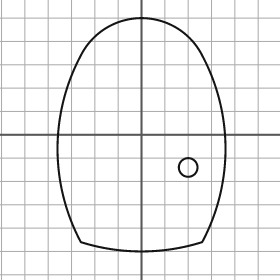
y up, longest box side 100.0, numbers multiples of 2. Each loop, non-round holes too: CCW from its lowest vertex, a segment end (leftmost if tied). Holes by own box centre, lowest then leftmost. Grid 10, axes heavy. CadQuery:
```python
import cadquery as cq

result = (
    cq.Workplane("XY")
    .moveTo(-26.0, -46.0)
    .threePointArc((0.0, -50.0), (26.0, -46.0))
    .threePointArc((36.0, -6.0), (26.0, 34.0))
    .threePointArc((0.0, 50.0), (-26.0, 34.0))
    .threePointArc((-36.0, -6.0), (-26.0, -46.0))
    .close()
    .moveTo(20.0, -14.0)
    .circle(4.0)
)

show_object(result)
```